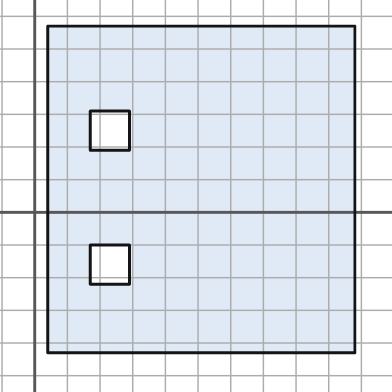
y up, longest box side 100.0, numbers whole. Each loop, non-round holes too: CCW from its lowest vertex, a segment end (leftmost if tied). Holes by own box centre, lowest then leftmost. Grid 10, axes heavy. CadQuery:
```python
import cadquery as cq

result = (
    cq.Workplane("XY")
    .moveTo(4.0, -43.0)
    .lineTo(98.0, -43.0)
    .lineTo(98.0, 57.0)
    .lineTo(4.0, 57.0)
    .close()
    .moveTo(17.0, -22.0)
    .lineTo(29.0, -22.0)
    .lineTo(29.0, -10.0)
    .lineTo(17.0, -10.0)
    .close()
    .moveTo(17.0, 19.0)
    .lineTo(29.0, 19.0)
    .lineTo(29.0, 31.0)
    .lineTo(17.0, 31.0)
    .close()
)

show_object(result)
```